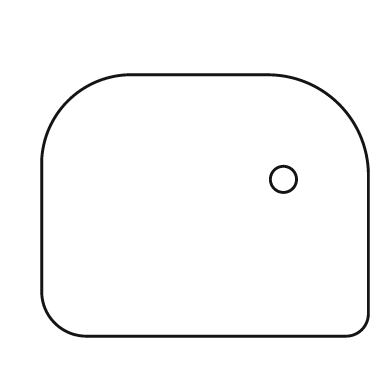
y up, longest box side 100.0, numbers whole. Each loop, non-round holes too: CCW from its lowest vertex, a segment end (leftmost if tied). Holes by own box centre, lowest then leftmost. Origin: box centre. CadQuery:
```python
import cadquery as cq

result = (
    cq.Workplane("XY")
    .moveTo(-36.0, -40.0)
    .lineTo(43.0, -40.0)
    .threePointArc((48.0, -38.0), (50.0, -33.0))
    .lineTo(50.0, 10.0)
    .threePointArc((41.0, 31.0), (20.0, 40.0))
    .lineTo(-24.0, 40.0)
    .threePointArc((-42.0, 32.0), (-50.0, 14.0))
    .lineTo(-50.0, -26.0)
    .threePointArc((-46.0, -36.0), (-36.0, -40.0))
    .close()
    .moveTo(24.0, 8.0)
    .circle(4.0)
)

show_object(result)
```